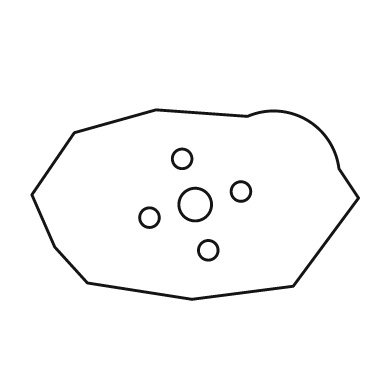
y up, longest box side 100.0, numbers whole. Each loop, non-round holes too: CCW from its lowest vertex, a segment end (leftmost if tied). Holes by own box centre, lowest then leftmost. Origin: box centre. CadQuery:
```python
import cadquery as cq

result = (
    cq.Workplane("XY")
    .moveTo(-1.0, -29.0)
    .lineTo(30.0, -25.0)
    .lineTo(50.0, 2.0)
    .lineTo(44.0, 11.0)
    .threePointArc((34.0, 26.0), (16.0, 27.0))
    .lineTo(-12.0, 29.0)
    .lineTo(-37.0, 22.0)
    .lineTo(-50.0, 3.0)
    .lineTo(-43.0, -13.0)
    .lineTo(-33.0, -24.0)
    .close()
    .moveTo(4.0, -14.0)
    .circle(3.0)
    .moveTo(-14.0, -4.0)
    .circle(3.0)
    .moveTo(0.0, 0.0)
    .circle(5.0)
    .moveTo(14.0, 4.0)
    .circle(3.0)
    .moveTo(-4.0, 14.0)
    .circle(3.0)
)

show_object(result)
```